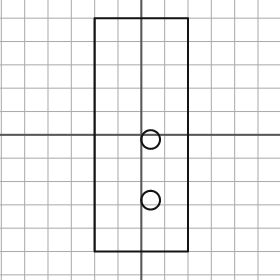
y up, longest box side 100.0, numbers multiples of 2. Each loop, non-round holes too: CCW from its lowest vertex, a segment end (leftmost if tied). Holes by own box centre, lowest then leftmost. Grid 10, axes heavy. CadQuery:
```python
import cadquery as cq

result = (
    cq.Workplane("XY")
    .moveTo(-20.0, -50.0)
    .lineTo(20.0, -50.0)
    .lineTo(20.0, 50.0)
    .lineTo(-20.0, 50.0)
    .close()
    .moveTo(4.0, -28.0)
    .circle(4.0)
    .moveTo(4.0, -2.0)
    .circle(4.0)
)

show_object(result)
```